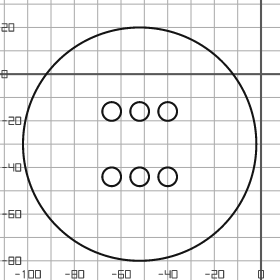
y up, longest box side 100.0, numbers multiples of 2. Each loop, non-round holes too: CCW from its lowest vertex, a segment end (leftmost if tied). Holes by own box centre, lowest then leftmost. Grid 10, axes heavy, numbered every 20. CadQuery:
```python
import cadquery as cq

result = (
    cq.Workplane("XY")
    .moveTo(-52.0, -30.0)
    .circle(50.0)
    .moveTo(-64.0, -44.0)
    .circle(4.0)
    .moveTo(-52.0, -44.0)
    .circle(4.0)
    .moveTo(-40.0, -44.0)
    .circle(4.0)
    .moveTo(-64.0, -16.0)
    .circle(4.0)
    .moveTo(-52.0, -16.0)
    .circle(4.0)
    .moveTo(-40.0, -16.0)
    .circle(4.0)
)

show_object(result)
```